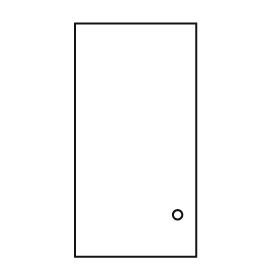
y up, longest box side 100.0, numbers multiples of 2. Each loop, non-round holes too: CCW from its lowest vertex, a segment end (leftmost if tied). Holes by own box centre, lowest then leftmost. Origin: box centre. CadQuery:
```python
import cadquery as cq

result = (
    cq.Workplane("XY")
    .moveTo(-26.0, -50.0)
    .lineTo(26.0, -50.0)
    .lineTo(26.0, 50.0)
    .lineTo(-26.0, 50.0)
    .close()
    .moveTo(18.0, -32.0)
    .circle(2.0)
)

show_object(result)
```